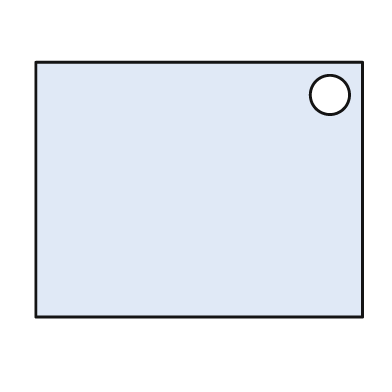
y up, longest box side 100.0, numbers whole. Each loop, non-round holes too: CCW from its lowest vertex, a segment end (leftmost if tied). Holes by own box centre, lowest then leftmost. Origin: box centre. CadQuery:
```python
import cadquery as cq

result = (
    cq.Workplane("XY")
    .moveTo(-50.0, -39.0)
    .lineTo(50.0, -39.0)
    .lineTo(50.0, 39.0)
    .lineTo(-50.0, 39.0)
    .close()
    .moveTo(40.0, 29.0)
    .circle(6.0)
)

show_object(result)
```